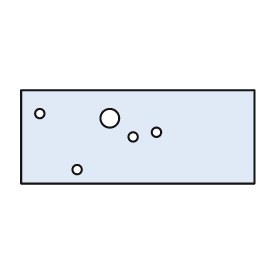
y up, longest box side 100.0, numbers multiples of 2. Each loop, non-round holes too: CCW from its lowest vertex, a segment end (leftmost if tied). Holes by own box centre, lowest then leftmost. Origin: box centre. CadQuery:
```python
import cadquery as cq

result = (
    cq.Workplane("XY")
    .moveTo(-50.0, -20.0)
    .lineTo(50.0, -20.0)
    .lineTo(50.0, 20.0)
    .lineTo(-50.0, 20.0)
    .close()
    .moveTo(-26.0, -14.0)
    .circle(2.0)
    .moveTo(-2.0, 0.0)
    .circle(2.0)
    .moveTo(8.0, 2.0)
    .circle(2.0)
    .moveTo(-12.0, 8.0)
    .circle(4.0)
    .moveTo(-42.0, 10.0)
    .circle(2.0)
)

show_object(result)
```